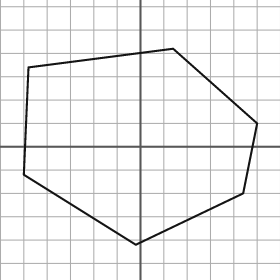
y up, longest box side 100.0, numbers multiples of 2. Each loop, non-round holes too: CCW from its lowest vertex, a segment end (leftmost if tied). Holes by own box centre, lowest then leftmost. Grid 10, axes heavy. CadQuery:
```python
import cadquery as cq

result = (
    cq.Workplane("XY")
    .moveTo(-2.0, -42.0)
    .lineTo(44.0, -20.0)
    .lineTo(50.0, 10.0)
    .lineTo(14.0, 42.0)
    .lineTo(-48.0, 34.0)
    .lineTo(-50.0, -12.0)
    .close()
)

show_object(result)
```